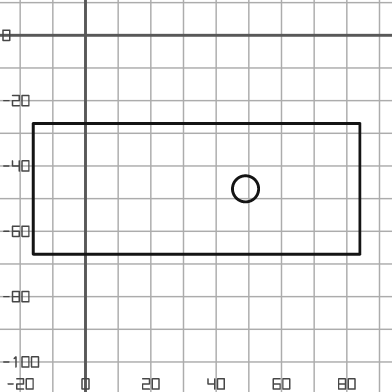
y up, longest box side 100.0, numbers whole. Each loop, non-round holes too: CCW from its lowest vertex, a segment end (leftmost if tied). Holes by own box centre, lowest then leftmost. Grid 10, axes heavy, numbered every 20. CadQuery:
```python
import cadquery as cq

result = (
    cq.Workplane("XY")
    .moveTo(-16.0, -67.0)
    .lineTo(84.0, -67.0)
    .lineTo(84.0, -27.0)
    .lineTo(-16.0, -27.0)
    .close()
    .moveTo(49.0, -47.0)
    .circle(4.0)
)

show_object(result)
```